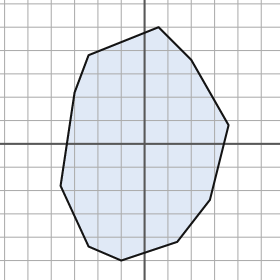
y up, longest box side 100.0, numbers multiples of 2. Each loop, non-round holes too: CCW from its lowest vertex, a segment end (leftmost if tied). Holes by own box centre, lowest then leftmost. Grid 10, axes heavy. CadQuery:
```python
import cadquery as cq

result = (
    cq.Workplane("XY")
    .moveTo(-10.0, -50.0)
    .lineTo(14.0, -42.0)
    .lineTo(28.0, -24.0)
    .lineTo(36.0, 8.0)
    .lineTo(20.0, 36.0)
    .lineTo(6.0, 50.0)
    .lineTo(-24.0, 38.0)
    .lineTo(-30.0, 22.0)
    .lineTo(-36.0, -18.0)
    .lineTo(-24.0, -44.0)
    .close()
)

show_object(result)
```